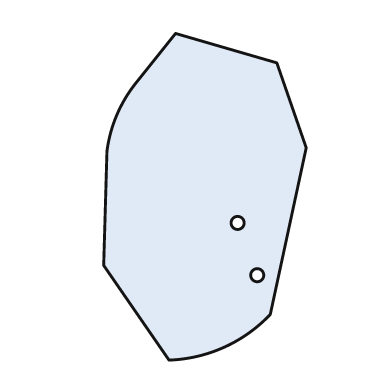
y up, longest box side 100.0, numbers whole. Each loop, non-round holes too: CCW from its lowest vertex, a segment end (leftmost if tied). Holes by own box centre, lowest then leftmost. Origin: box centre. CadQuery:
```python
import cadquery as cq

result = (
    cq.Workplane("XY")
    .moveTo(-11.0, -50.0)
    .threePointArc((6.0, -46.0), (20.0, -36.0))
    .lineTo(31.0, 15.0)
    .lineTo(22.0, 41.0)
    .lineTo(-9.0, 50.0)
    .lineTo(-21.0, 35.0)
    .threePointArc((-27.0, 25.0), (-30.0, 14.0))
    .lineTo(-31.0, -21.0)
    .close()
    .moveTo(16.0, -24.0)
    .circle(2.0)
    .moveTo(10.0, -8.0)
    .circle(2.0)
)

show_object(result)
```